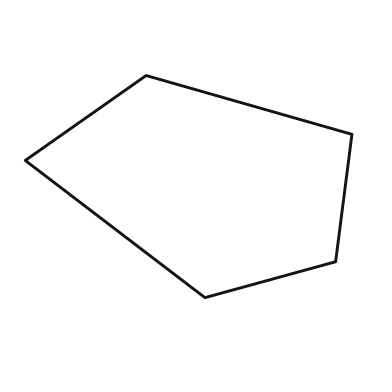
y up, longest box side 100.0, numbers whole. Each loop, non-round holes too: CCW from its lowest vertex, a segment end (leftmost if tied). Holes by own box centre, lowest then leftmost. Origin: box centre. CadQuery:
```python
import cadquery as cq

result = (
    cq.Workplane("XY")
    .moveTo(5.0, -34.0)
    .lineTo(45.0, -23.0)
    .lineTo(50.0, 16.0)
    .lineTo(-13.0, 34.0)
    .lineTo(-50.0, 8.0)
    .close()
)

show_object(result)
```